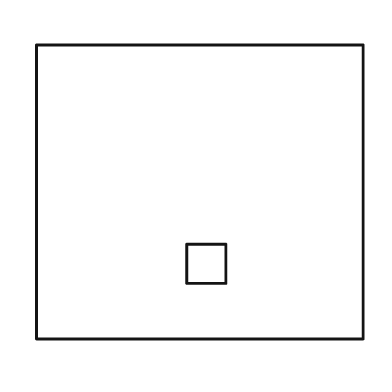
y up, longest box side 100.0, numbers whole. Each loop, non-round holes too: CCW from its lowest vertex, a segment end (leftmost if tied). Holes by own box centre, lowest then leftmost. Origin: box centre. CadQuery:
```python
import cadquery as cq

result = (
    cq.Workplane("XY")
    .moveTo(-50.0, -45.0)
    .lineTo(50.0, -45.0)
    .lineTo(50.0, 45.0)
    .lineTo(-50.0, 45.0)
    .close()
    .moveTo(-4.0, -28.0)
    .lineTo(8.0, -28.0)
    .lineTo(8.0, -16.0)
    .lineTo(-4.0, -16.0)
    .close()
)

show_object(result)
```